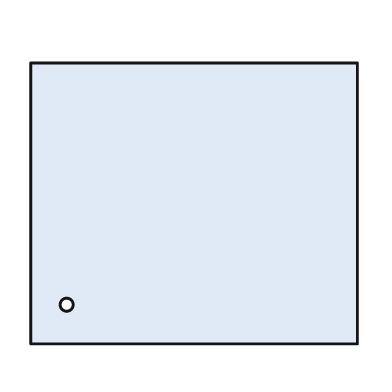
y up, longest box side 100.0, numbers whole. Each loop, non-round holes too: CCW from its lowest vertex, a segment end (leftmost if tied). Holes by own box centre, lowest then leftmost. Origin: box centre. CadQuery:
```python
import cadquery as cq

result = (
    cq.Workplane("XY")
    .moveTo(-50.0, -43.0)
    .lineTo(50.0, -43.0)
    .lineTo(50.0, 43.0)
    .lineTo(-50.0, 43.0)
    .close()
    .moveTo(-39.0, -31.0)
    .circle(2.0)
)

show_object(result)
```